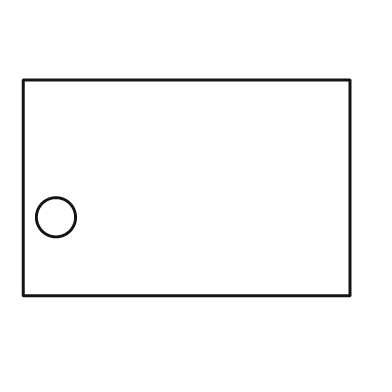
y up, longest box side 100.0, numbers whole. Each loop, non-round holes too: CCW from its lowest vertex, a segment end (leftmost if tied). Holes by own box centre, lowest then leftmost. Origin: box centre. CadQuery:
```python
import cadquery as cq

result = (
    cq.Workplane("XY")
    .moveTo(-50.0, -33.0)
    .lineTo(50.0, -33.0)
    .lineTo(50.0, 33.0)
    .lineTo(-50.0, 33.0)
    .close()
    .moveTo(-40.0, -9.0)
    .circle(6.0)
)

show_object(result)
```